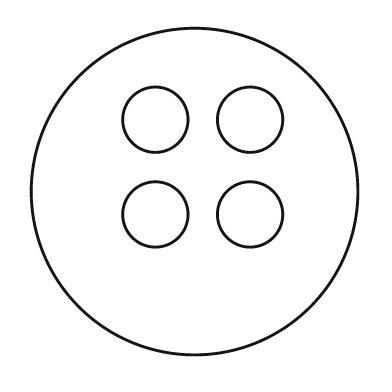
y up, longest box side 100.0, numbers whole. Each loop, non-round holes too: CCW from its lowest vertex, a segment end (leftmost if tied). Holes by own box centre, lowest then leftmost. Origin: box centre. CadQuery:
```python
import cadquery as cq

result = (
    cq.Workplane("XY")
    .moveTo(0.0, 0.0)
    .circle(50.0)
    .moveTo(-12.0, -7.0)
    .circle(10.0)
    .moveTo(17.0, -7.0)
    .circle(10.0)
    .moveTo(-12.0, 22.0)
    .circle(10.0)
    .moveTo(17.0, 22.0)
    .circle(10.0)
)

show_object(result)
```